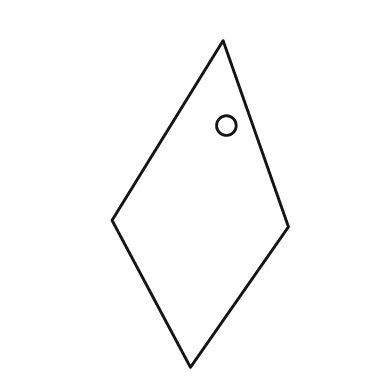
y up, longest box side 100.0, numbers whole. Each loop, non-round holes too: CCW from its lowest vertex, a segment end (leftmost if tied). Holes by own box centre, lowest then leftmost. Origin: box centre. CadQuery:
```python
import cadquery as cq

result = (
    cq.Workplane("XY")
    .moveTo(-3.0, -50.0)
    .lineTo(27.0, -7.0)
    .lineTo(7.0, 50.0)
    .lineTo(-27.0, -5.0)
    .close()
    .moveTo(8.0, 24.0)
    .circle(3.0)
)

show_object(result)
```